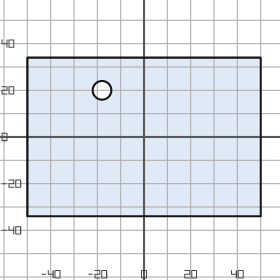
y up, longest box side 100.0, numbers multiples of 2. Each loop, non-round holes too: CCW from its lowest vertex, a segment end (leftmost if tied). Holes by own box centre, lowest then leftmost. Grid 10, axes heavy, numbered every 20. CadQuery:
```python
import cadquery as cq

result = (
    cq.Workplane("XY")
    .moveTo(-50.0, -34.0)
    .lineTo(50.0, -34.0)
    .lineTo(50.0, 34.0)
    .lineTo(-50.0, 34.0)
    .close()
    .moveTo(-18.0, 20.0)
    .circle(4.0)
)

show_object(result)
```